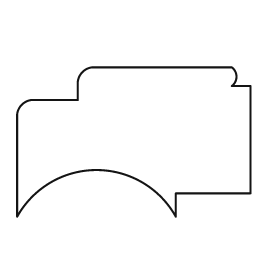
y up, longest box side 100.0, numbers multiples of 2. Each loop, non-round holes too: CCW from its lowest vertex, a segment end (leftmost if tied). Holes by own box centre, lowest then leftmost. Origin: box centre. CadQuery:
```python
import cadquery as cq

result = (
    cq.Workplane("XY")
    .moveTo(-50.0, -32.0)
    .threePointArc((-16.0, -12.0), (18.0, -32.0))
    .lineTo(18.0, -22.0)
    .lineTo(50.0, -22.0)
    .lineTo(50.0, 24.0)
    .lineTo(42.0, 24.0)
    .threePointArc((44.0, 28.0), (42.0, 32.0))
    .lineTo(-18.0, 32.0)
    .threePointArc((-22.0, 30.0), (-24.0, 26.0))
    .lineTo(-24.0, 18.0)
    .lineTo(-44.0, 18.0)
    .threePointArc((-48.0, 16.0), (-50.0, 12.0))
    .close()
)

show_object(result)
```